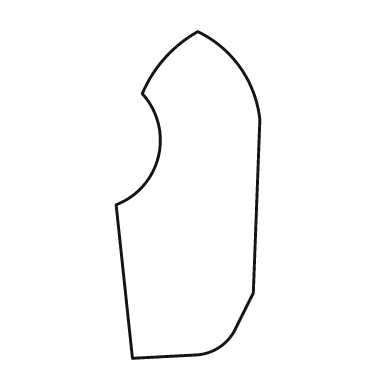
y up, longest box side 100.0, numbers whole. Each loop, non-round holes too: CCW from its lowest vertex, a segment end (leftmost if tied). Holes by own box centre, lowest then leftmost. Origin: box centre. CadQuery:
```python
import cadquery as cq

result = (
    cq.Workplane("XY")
    .moveTo(-17.0, -50.0)
    .lineTo(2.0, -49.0)
    .threePointArc((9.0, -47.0), (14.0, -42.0))
    .lineTo(20.0, -30.0)
    .lineTo(22.0, 23.0)
    .threePointArc((16.0, 39.0), (3.0, 50.0))
    .threePointArc((-7.0, 42.0), (-14.0, 31.0))
    .threePointArc((-9.0, 12.0), (-22.0, -3.0))
    .close()
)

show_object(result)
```